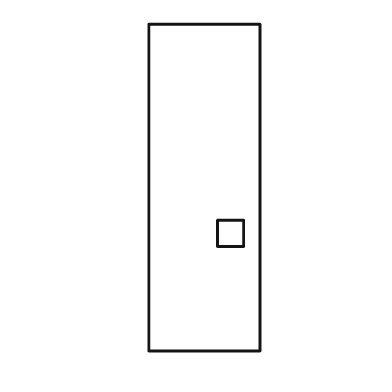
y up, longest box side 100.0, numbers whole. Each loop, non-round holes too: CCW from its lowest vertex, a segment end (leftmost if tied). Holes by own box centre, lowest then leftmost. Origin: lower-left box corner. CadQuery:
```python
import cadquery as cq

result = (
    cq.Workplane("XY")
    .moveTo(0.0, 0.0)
    .lineTo(34.0, 0.0)
    .lineTo(34.0, 100.0)
    .lineTo(0.0, 100.0)
    .close()
    .moveTo(21.0, 32.0)
    .lineTo(29.0, 32.0)
    .lineTo(29.0, 40.0)
    .lineTo(21.0, 40.0)
    .close()
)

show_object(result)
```